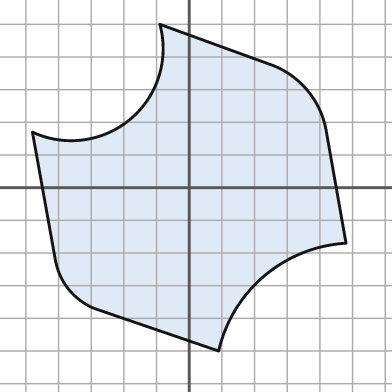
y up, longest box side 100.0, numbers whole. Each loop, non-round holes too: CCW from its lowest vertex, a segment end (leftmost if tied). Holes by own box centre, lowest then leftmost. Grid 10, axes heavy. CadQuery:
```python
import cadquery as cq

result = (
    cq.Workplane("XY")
    .moveTo(9.0, -50.0)
    .threePointArc((23.0, -27.0), (48.0, -17.0))
    .lineTo(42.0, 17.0)
    .threePointArc((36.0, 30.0), (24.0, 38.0))
    .lineTo(-9.0, 50.0)
    .threePointArc((-18.0, 21.0), (-48.0, 17.0))
    .lineTo(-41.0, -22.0)
    .threePointArc((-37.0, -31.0), (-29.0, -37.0))
    .close()
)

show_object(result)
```